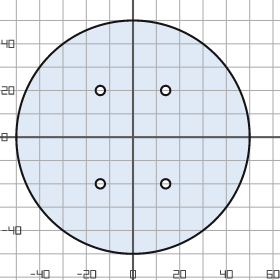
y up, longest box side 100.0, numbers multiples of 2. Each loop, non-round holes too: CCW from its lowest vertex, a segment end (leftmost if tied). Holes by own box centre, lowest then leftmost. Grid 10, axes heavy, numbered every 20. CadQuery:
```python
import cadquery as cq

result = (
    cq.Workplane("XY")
    .moveTo(0.0, 0.0)
    .circle(50.0)
    .moveTo(-14.0, -20.0)
    .circle(2.0)
    .moveTo(14.0, -20.0)
    .circle(2.0)
    .moveTo(-14.0, 20.0)
    .circle(2.0)
    .moveTo(14.0, 20.0)
    .circle(2.0)
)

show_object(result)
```